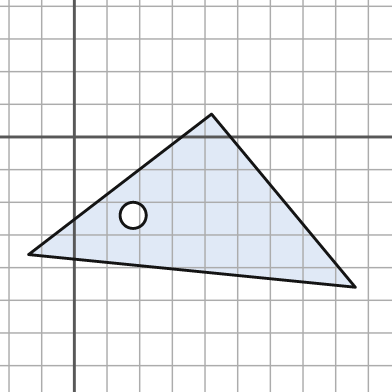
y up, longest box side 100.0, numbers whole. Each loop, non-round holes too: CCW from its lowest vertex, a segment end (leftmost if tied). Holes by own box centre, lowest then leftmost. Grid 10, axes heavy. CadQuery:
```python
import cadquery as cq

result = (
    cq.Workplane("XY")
    .moveTo(86.0, -46.0)
    .lineTo(42.0, 7.0)
    .lineTo(-14.0, -36.0)
    .close()
    .moveTo(18.0, -24.0)
    .circle(4.0)
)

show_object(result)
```